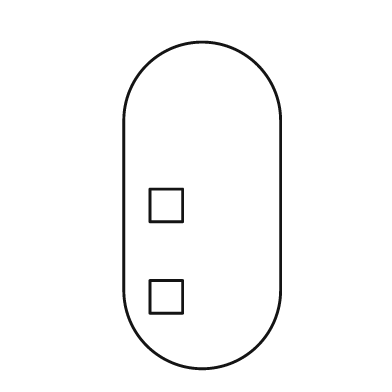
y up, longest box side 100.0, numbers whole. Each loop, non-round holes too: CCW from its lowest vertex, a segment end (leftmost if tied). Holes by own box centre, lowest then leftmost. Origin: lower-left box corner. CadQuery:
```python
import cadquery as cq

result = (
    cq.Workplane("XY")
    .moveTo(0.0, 24.0)
    .threePointArc((24.0, 0.0), (48.0, 24.0))
    .lineTo(48.0, 76.0)
    .threePointArc((24.0, 100.0), (0.0, 76.0))
    .close()
    .moveTo(8.0, 17.0)
    .lineTo(18.0, 17.0)
    .lineTo(18.0, 27.0)
    .lineTo(8.0, 27.0)
    .close()
    .moveTo(8.0, 45.0)
    .lineTo(18.0, 45.0)
    .lineTo(18.0, 55.0)
    .lineTo(8.0, 55.0)
    .close()
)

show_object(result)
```